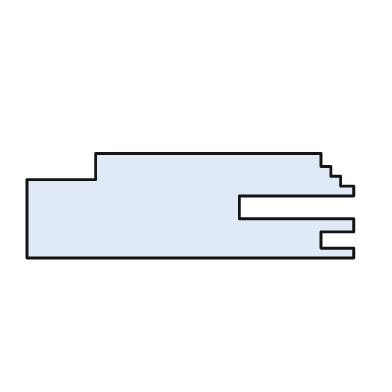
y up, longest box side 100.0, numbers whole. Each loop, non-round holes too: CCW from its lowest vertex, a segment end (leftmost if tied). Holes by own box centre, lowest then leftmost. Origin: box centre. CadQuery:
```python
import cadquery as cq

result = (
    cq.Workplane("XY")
    .moveTo(-50.0, -16.0)
    .lineTo(50.0, -16.0)
    .lineTo(50.0, -13.0)
    .lineTo(40.0, -13.0)
    .lineTo(40.0, -8.0)
    .lineTo(50.0, -8.0)
    .lineTo(50.0, -4.0)
    .lineTo(15.0, -4.0)
    .lineTo(15.0, 3.0)
    .lineTo(50.0, 3.0)
    .lineTo(50.0, 6.0)
    .lineTo(46.0, 6.0)
    .lineTo(46.0, 9.0)
    .lineTo(43.0, 9.0)
    .lineTo(43.0, 12.0)
    .lineTo(40.0, 12.0)
    .lineTo(40.0, 16.0)
    .lineTo(-29.0, 16.0)
    .lineTo(-29.0, 8.0)
    .lineTo(-50.0, 8.0)
    .close()
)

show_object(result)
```